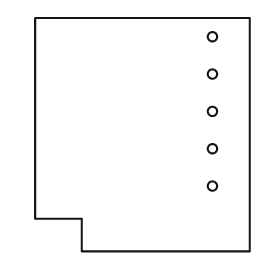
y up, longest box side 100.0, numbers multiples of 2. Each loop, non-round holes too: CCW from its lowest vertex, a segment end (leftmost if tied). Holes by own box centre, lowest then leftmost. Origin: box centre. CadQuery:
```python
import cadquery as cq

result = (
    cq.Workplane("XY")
    .moveTo(-26.0, -50.0)
    .lineTo(46.0, -50.0)
    .lineTo(46.0, 50.0)
    .lineTo(-46.0, 50.0)
    .lineTo(-46.0, -36.0)
    .lineTo(-26.0, -36.0)
    .close()
    .moveTo(30.0, -22.0)
    .circle(2.0)
    .moveTo(30.0, -6.0)
    .circle(2.0)
    .moveTo(30.0, 10.0)
    .circle(2.0)
    .moveTo(30.0, 26.0)
    .circle(2.0)
    .moveTo(30.0, 42.0)
    .circle(2.0)
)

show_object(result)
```